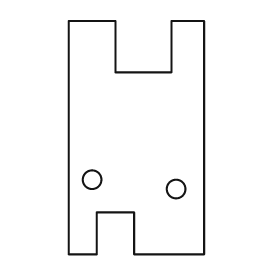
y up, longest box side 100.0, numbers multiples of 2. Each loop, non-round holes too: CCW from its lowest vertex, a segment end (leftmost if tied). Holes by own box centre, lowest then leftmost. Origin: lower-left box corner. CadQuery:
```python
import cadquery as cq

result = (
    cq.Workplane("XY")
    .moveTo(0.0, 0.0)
    .lineTo(12.0, 0.0)
    .lineTo(12.0, 18.0)
    .lineTo(28.0, 18.0)
    .lineTo(28.0, 0.0)
    .lineTo(58.0, 0.0)
    .lineTo(58.0, 100.0)
    .lineTo(44.0, 100.0)
    .lineTo(44.0, 78.0)
    .lineTo(20.0, 78.0)
    .lineTo(20.0, 100.0)
    .lineTo(0.0, 100.0)
    .close()
    .moveTo(46.0, 28.0)
    .circle(4.0)
    .moveTo(10.0, 32.0)
    .circle(4.0)
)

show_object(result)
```